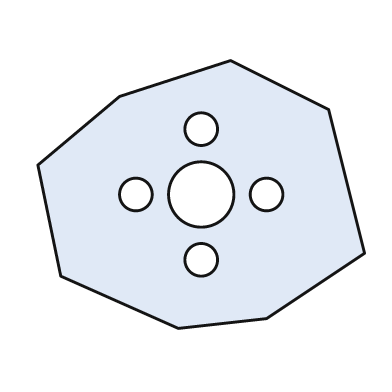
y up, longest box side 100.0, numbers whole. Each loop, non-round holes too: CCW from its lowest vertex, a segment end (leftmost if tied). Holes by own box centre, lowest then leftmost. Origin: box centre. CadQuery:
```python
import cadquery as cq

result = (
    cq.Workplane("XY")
    .moveTo(-7.0, -41.0)
    .lineTo(20.0, -38.0)
    .lineTo(50.0, -18.0)
    .lineTo(39.0, 26.0)
    .lineTo(9.0, 41.0)
    .lineTo(-25.0, 30.0)
    .lineTo(-50.0, 9.0)
    .lineTo(-43.0, -25.0)
    .close()
    .moveTo(0.0, -20.0)
    .circle(5.0)
    .moveTo(-20.0, 0.0)
    .circle(5.0)
    .moveTo(0.0, 0.0)
    .circle(10.0)
    .moveTo(20.0, 0.0)
    .circle(5.0)
    .moveTo(0.0, 20.0)
    .circle(5.0)
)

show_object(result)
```